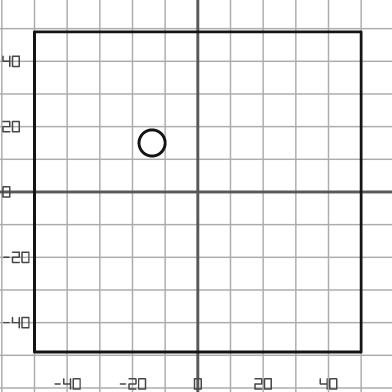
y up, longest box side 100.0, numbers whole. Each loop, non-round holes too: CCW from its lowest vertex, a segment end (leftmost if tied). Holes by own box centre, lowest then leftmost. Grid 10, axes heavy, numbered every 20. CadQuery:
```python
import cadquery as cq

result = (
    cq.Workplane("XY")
    .moveTo(-50.0, -49.0)
    .lineTo(50.0, -49.0)
    .lineTo(50.0, 49.0)
    .lineTo(-50.0, 49.0)
    .close()
    .moveTo(-14.0, 15.0)
    .circle(4.0)
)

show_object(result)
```